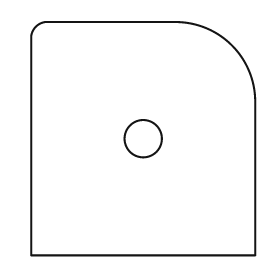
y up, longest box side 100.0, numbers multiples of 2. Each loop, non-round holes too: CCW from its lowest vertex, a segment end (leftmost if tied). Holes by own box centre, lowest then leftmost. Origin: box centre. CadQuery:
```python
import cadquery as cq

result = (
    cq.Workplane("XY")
    .moveTo(-48.0, -50.0)
    .lineTo(48.0, -50.0)
    .lineTo(48.0, 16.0)
    .threePointArc((38.0, 40.0), (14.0, 50.0))
    .lineTo(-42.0, 50.0)
    .threePointArc((-46.0, 48.0), (-48.0, 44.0))
    .close()
    .moveTo(0.0, 0.0)
    .circle(8.0)
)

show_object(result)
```